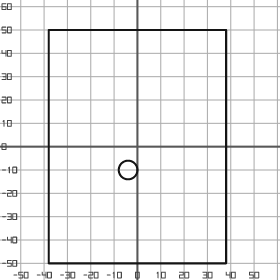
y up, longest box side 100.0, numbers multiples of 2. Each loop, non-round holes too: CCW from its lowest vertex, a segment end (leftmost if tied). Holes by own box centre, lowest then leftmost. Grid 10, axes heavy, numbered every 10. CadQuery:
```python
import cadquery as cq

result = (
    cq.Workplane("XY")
    .moveTo(-38.0, -50.0)
    .lineTo(38.0, -50.0)
    .lineTo(38.0, 50.0)
    .lineTo(-38.0, 50.0)
    .close()
    .moveTo(-4.0, -10.0)
    .circle(4.0)
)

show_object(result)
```